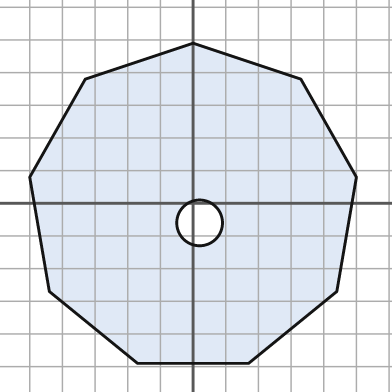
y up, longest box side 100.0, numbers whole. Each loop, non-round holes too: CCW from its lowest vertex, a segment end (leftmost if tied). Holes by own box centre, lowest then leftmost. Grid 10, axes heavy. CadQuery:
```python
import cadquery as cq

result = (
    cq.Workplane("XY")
    .moveTo(-17.0, -49.0)
    .lineTo(17.0, -49.0)
    .lineTo(44.0, -27.0)
    .lineTo(50.0, 8.0)
    .lineTo(33.0, 38.0)
    .lineTo(0.0, 49.0)
    .lineTo(-33.0, 38.0)
    .lineTo(-50.0, 8.0)
    .lineTo(-44.0, -27.0)
    .close()
    .moveTo(2.0, -6.0)
    .circle(7.0)
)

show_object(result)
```